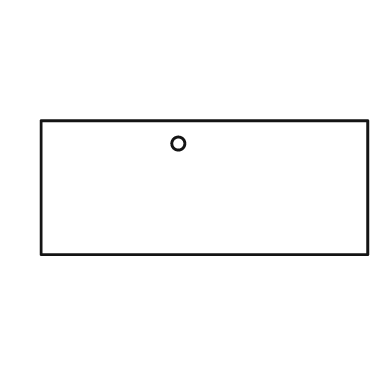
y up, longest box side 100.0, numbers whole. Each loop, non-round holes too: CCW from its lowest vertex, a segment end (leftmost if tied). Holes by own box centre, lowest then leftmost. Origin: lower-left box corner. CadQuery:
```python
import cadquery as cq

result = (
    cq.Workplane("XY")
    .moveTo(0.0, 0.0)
    .lineTo(100.0, 0.0)
    .lineTo(100.0, 41.0)
    .lineTo(0.0, 41.0)
    .close()
    .moveTo(42.0, 34.0)
    .circle(2.0)
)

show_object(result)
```